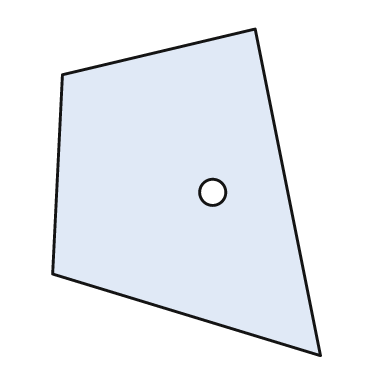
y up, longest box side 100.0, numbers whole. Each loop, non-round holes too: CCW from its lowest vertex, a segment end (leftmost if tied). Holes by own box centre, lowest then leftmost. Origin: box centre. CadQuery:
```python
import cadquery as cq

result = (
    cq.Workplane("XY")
    .moveTo(41.0, -50.0)
    .lineTo(21.0, 50.0)
    .lineTo(-38.0, 36.0)
    .lineTo(-41.0, -25.0)
    .close()
    .moveTo(8.0, 0.0)
    .circle(4.0)
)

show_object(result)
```